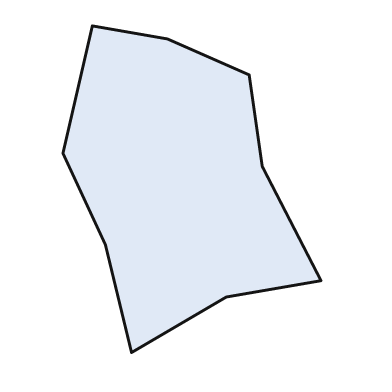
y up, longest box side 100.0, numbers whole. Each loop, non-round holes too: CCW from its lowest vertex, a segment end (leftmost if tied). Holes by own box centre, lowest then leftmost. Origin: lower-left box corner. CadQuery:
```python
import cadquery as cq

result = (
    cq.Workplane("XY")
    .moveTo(21.0, 0.0)
    .lineTo(50.0, 17.0)
    .lineTo(79.0, 22.0)
    .lineTo(61.0, 57.0)
    .lineTo(57.0, 85.0)
    .lineTo(32.0, 96.0)
    .lineTo(9.0, 100.0)
    .lineTo(0.0, 61.0)
    .lineTo(13.0, 33.0)
    .close()
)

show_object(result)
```